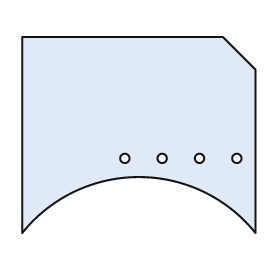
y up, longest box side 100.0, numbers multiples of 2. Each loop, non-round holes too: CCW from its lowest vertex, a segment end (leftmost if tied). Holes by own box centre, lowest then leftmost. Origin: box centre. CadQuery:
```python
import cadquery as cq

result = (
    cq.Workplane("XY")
    .moveTo(-50.0, -42.0)
    .threePointArc((0.0, -18.0), (50.0, -42.0))
    .lineTo(50.0, 28.0)
    .lineTo(36.0, 42.0)
    .lineTo(-50.0, 42.0)
    .close()
    .moveTo(-6.0, -10.0)
    .circle(2.0)
    .moveTo(10.0, -10.0)
    .circle(2.0)
    .moveTo(26.0, -10.0)
    .circle(2.0)
    .moveTo(42.0, -10.0)
    .circle(2.0)
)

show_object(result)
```